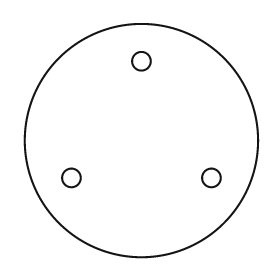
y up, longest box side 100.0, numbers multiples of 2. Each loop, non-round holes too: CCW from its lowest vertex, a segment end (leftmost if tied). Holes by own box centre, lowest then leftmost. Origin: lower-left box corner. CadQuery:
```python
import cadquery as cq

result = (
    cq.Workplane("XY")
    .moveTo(50.0, 50.0)
    .circle(50.0)
    .moveTo(20.0, 34.0)
    .circle(4.0)
    .moveTo(80.0, 34.0)
    .circle(4.0)
    .moveTo(50.0, 84.0)
    .circle(4.0)
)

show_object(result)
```